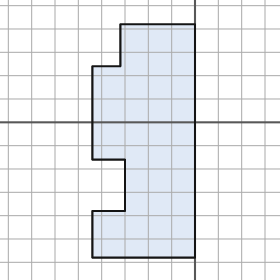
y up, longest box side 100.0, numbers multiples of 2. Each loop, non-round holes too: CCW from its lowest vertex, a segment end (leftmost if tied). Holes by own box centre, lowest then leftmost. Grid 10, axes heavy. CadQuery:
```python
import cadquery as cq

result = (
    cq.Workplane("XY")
    .moveTo(-44.0, -58.0)
    .lineTo(0.0, -58.0)
    .lineTo(0.0, 42.0)
    .lineTo(-32.0, 42.0)
    .lineTo(-32.0, 24.0)
    .lineTo(-44.0, 24.0)
    .lineTo(-44.0, -16.0)
    .lineTo(-30.0, -16.0)
    .lineTo(-30.0, -38.0)
    .lineTo(-44.0, -38.0)
    .close()
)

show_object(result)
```